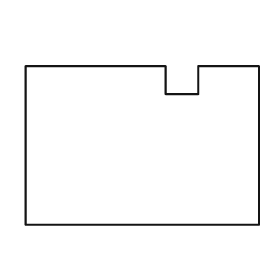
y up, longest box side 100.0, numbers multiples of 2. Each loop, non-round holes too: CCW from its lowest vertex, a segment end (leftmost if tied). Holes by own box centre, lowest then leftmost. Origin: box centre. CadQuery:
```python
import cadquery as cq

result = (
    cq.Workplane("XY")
    .moveTo(-50.0, -34.0)
    .lineTo(50.0, -34.0)
    .lineTo(50.0, 34.0)
    .lineTo(24.0, 34.0)
    .lineTo(24.0, 22.0)
    .lineTo(10.0, 22.0)
    .lineTo(10.0, 34.0)
    .lineTo(-50.0, 34.0)
    .close()
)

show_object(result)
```